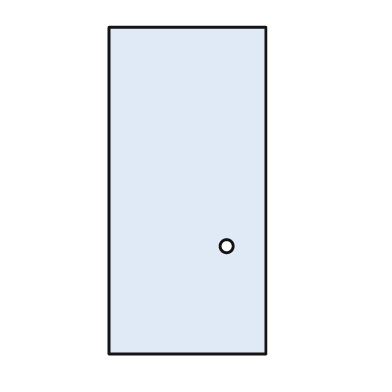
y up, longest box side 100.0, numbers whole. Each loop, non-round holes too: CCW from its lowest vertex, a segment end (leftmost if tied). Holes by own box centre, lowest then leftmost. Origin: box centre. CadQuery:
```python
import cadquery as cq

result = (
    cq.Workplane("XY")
    .moveTo(-24.0, -50.0)
    .lineTo(24.0, -50.0)
    .lineTo(24.0, 50.0)
    .lineTo(-24.0, 50.0)
    .close()
    .moveTo(12.0, -17.0)
    .circle(2.0)
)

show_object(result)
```